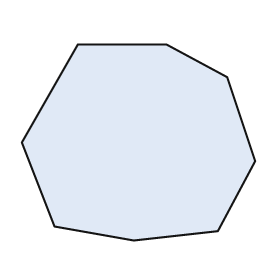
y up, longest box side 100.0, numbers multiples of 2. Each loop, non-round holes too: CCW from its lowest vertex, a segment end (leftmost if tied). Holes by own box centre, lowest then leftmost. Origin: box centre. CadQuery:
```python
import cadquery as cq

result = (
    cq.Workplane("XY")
    .moveTo(-2.0, -42.0)
    .lineTo(34.0, -38.0)
    .lineTo(50.0, -8.0)
    .lineTo(38.0, 28.0)
    .lineTo(12.0, 42.0)
    .lineTo(-26.0, 42.0)
    .lineTo(-50.0, 0.0)
    .lineTo(-36.0, -36.0)
    .close()
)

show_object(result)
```